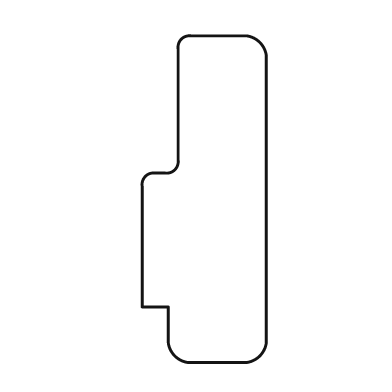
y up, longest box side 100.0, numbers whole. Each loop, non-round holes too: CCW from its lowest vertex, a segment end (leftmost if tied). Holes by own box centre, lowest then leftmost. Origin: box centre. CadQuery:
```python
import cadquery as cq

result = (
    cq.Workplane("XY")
    .moveTo(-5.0, -50.0)
    .lineTo(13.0, -50.0)
    .threePointArc((17.0, -48.0), (19.0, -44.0))
    .lineTo(19.0, 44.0)
    .threePointArc((17.0, 48.0), (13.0, 50.0))
    .lineTo(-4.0, 50.0)
    .threePointArc((-7.0, 49.0), (-8.0, 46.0))
    .lineTo(-8.0, 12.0)
    .threePointArc((-9.0, 9.0), (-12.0, 8.0))
    .lineTo(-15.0, 8.0)
    .threePointArc((-18.0, 7.0), (-19.0, 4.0))
    .lineTo(-19.0, -33.0)
    .lineTo(-11.0, -33.0)
    .lineTo(-11.0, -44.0)
    .threePointArc((-9.0, -48.0), (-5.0, -50.0))
    .close()
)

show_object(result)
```